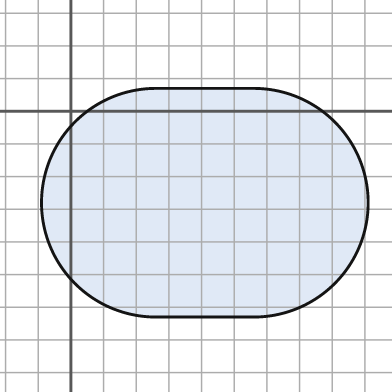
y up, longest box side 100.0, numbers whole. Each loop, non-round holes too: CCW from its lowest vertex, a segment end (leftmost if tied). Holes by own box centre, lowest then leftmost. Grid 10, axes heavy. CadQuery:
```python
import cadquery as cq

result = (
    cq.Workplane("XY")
    .moveTo(26.0, -63.0)
    .lineTo(56.0, -63.0)
    .threePointArc((91.0, -28.0), (56.0, 7.0))
    .lineTo(26.0, 7.0)
    .threePointArc((-9.0, -28.0), (26.0, -63.0))
    .close()
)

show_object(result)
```